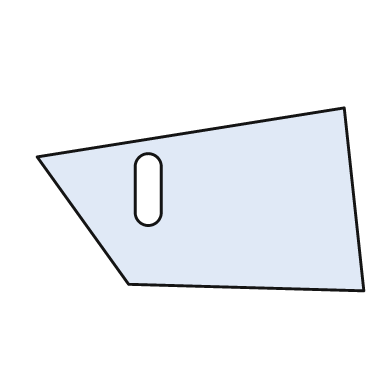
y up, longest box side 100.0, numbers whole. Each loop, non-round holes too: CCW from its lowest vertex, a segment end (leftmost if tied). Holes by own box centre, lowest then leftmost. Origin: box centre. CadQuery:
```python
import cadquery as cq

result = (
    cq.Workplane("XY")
    .moveTo(50.0, -28.0)
    .lineTo(44.0, 28.0)
    .lineTo(-50.0, 13.0)
    .lineTo(-22.0, -26.0)
    .close()
    .moveTo(-20.0, -4.0)
    .threePointArc((-16.0, -8.0), (-12.0, -4.0))
    .lineTo(-12.0, 10.0)
    .threePointArc((-16.0, 14.0), (-20.0, 10.0))
    .close()
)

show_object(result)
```